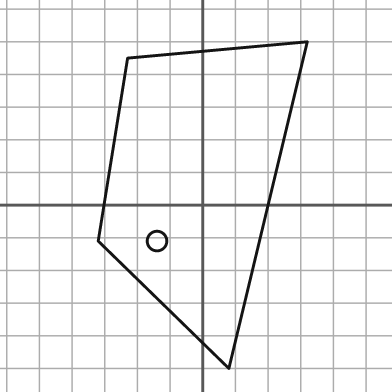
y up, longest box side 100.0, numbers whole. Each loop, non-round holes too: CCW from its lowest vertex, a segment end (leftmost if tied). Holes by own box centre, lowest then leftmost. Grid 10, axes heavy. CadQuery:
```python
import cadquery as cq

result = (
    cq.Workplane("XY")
    .moveTo(8.0, -50.0)
    .lineTo(32.0, 50.0)
    .lineTo(-23.0, 45.0)
    .lineTo(-32.0, -11.0)
    .close()
    .moveTo(-14.0, -11.0)
    .circle(3.0)
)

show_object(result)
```